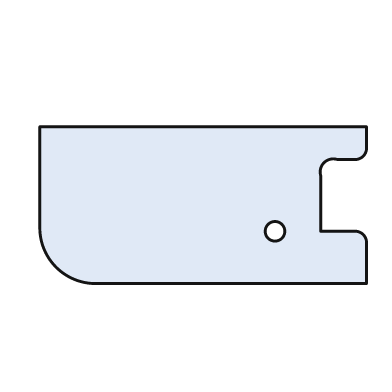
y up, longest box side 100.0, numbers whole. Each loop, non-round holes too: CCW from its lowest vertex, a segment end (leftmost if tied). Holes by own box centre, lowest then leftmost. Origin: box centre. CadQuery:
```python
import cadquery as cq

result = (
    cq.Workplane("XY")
    .moveTo(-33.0, -24.0)
    .lineTo(50.0, -24.0)
    .lineTo(50.0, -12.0)
    .threePointArc((49.0, -9.0), (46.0, -8.0))
    .lineTo(36.0, -8.0)
    .lineTo(36.0, 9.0)
    .threePointArc((37.0, 13.0), (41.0, 14.0))
    .lineTo(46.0, 14.0)
    .threePointArc((49.0, 15.0), (50.0, 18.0))
    .lineTo(50.0, 24.0)
    .lineTo(-50.0, 24.0)
    .lineTo(-50.0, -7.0)
    .threePointArc((-45.0, -19.0), (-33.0, -24.0))
    .close()
    .moveTo(22.0, -8.0)
    .circle(3.0)
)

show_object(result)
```